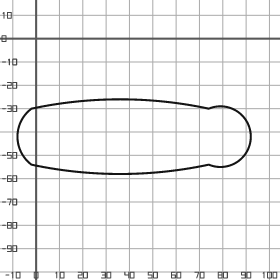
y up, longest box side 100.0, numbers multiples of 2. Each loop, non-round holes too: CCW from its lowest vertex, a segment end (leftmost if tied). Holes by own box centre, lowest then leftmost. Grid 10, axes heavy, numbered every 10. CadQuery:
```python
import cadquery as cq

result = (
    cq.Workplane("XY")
    .moveTo(-2.0, -54.0)
    .threePointArc((36.0, -58.0), (74.0, -54.0))
    .threePointArc((92.0, -42.0), (74.0, -30.0))
    .threePointArc((36.0, -26.0), (-2.0, -30.0))
    .threePointArc((-8.0, -42.0), (-2.0, -54.0))
    .close()
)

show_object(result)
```